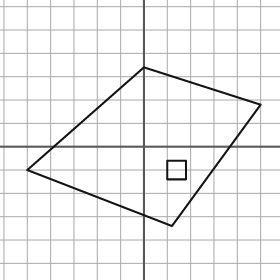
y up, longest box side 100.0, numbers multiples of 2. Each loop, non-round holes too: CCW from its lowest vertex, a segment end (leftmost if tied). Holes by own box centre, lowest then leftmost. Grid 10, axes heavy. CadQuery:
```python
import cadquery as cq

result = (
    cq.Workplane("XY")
    .moveTo(12.0, -34.0)
    .lineTo(50.0, 18.0)
    .lineTo(0.0, 34.0)
    .lineTo(-50.0, -10.0)
    .close()
    .moveTo(10.0, -14.0)
    .lineTo(18.0, -14.0)
    .lineTo(18.0, -6.0)
    .lineTo(10.0, -6.0)
    .close()
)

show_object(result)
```